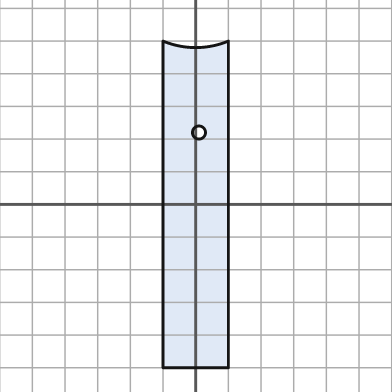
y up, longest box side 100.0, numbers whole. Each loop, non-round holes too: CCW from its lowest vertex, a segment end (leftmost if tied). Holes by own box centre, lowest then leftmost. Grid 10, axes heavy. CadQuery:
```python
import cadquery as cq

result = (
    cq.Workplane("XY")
    .moveTo(-10.0, -50.0)
    .lineTo(10.0, -50.0)
    .lineTo(10.0, 50.0)
    .threePointArc((0.0, 48.0), (-10.0, 50.0))
    .close()
    .moveTo(1.0, 22.0)
    .circle(2.0)
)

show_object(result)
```